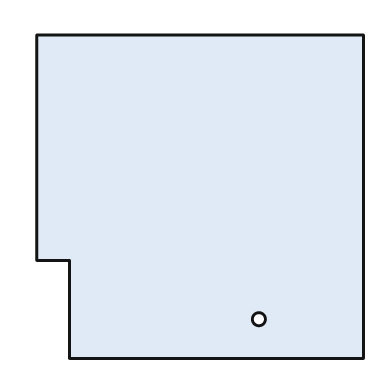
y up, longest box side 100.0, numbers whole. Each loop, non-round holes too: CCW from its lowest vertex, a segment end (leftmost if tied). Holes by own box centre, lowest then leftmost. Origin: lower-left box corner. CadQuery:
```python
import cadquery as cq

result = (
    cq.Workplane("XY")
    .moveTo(10.0, 0.0)
    .lineTo(100.0, 0.0)
    .lineTo(100.0, 99.0)
    .lineTo(0.0, 99.0)
    .lineTo(0.0, 30.0)
    .lineTo(10.0, 30.0)
    .close()
    .moveTo(68.0, 12.0)
    .circle(2.0)
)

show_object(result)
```